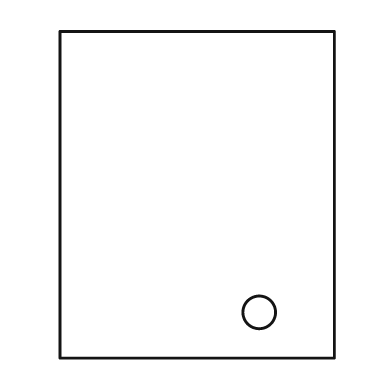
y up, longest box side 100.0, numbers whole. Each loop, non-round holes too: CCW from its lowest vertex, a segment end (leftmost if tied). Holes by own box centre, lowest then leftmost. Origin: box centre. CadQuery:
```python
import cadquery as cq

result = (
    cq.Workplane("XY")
    .moveTo(-42.0, -50.0)
    .lineTo(42.0, -50.0)
    .lineTo(42.0, 50.0)
    .lineTo(-42.0, 50.0)
    .close()
    .moveTo(19.0, -36.0)
    .circle(5.0)
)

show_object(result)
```